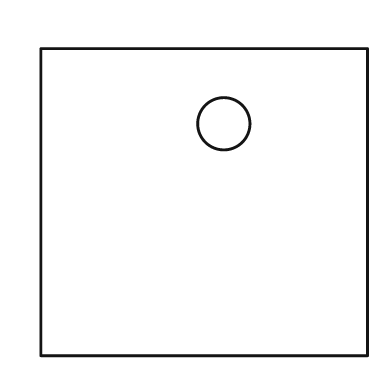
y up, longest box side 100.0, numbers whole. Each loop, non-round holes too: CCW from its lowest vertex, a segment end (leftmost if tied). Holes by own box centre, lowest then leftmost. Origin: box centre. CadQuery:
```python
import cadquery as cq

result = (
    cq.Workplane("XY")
    .moveTo(-50.0, -47.0)
    .lineTo(50.0, -47.0)
    .lineTo(50.0, 47.0)
    .lineTo(-50.0, 47.0)
    .close()
    .moveTo(6.0, 24.0)
    .circle(8.0)
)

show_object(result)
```